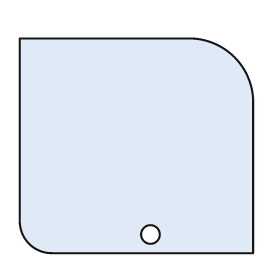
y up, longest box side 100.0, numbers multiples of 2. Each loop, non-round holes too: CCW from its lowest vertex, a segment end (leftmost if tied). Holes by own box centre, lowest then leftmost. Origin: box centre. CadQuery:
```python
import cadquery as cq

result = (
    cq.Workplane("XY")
    .moveTo(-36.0, -46.0)
    .lineTo(50.0, -46.0)
    .lineTo(50.0, 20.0)
    .threePointArc((42.0, 38.0), (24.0, 46.0))
    .lineTo(-50.0, 46.0)
    .lineTo(-50.0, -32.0)
    .threePointArc((-46.0, -42.0), (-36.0, -46.0))
    .close()
    .moveTo(6.0, -38.0)
    .circle(4.0)
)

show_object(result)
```